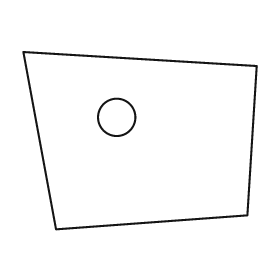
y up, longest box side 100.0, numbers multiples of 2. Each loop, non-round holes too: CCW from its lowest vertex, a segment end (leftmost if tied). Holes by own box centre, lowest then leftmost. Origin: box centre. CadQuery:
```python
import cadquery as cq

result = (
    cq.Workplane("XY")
    .moveTo(-36.0, -38.0)
    .lineTo(46.0, -32.0)
    .lineTo(50.0, 32.0)
    .lineTo(-50.0, 38.0)
    .close()
    .moveTo(-10.0, 10.0)
    .circle(8.0)
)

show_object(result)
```